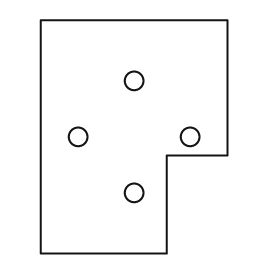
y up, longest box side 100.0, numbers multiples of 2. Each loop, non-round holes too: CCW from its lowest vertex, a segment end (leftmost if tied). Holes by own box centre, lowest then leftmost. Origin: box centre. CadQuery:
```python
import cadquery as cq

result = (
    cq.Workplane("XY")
    .moveTo(-40.0, -50.0)
    .lineTo(14.0, -50.0)
    .lineTo(14.0, -8.0)
    .lineTo(40.0, -8.0)
    .lineTo(40.0, 50.0)
    .lineTo(-40.0, 50.0)
    .close()
    .moveTo(0.0, -24.0)
    .circle(4.0)
    .moveTo(-24.0, 0.0)
    .circle(4.0)
    .moveTo(24.0, 0.0)
    .circle(4.0)
    .moveTo(0.0, 24.0)
    .circle(4.0)
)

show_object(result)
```